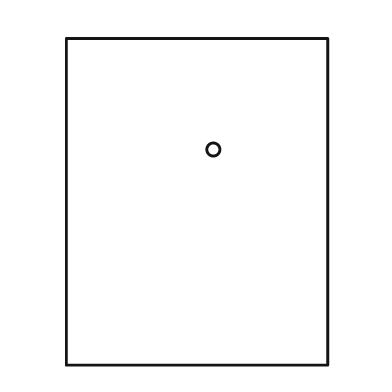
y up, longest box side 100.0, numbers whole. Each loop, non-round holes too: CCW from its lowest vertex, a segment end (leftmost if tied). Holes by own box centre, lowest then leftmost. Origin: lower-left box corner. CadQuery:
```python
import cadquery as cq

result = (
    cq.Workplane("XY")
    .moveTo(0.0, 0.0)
    .lineTo(80.0, 0.0)
    .lineTo(80.0, 100.0)
    .lineTo(0.0, 100.0)
    .close()
    .moveTo(45.0, 66.0)
    .circle(2.0)
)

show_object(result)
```